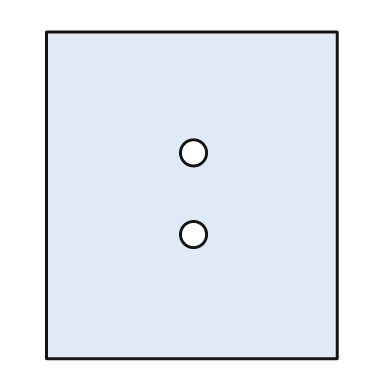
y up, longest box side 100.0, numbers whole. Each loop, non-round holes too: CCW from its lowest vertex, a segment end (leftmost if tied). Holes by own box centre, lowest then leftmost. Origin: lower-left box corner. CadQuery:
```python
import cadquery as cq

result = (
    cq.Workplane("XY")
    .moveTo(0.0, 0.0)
    .lineTo(89.0, 0.0)
    .lineTo(89.0, 100.0)
    .lineTo(0.0, 100.0)
    .close()
    .moveTo(45.0, 38.0)
    .circle(4.0)
    .moveTo(45.0, 63.0)
    .circle(4.0)
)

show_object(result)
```